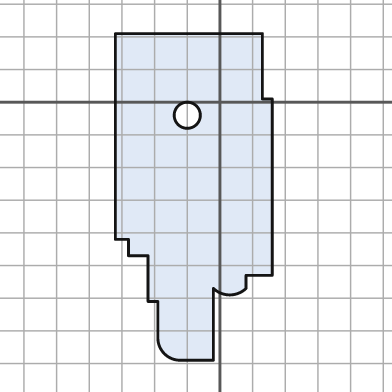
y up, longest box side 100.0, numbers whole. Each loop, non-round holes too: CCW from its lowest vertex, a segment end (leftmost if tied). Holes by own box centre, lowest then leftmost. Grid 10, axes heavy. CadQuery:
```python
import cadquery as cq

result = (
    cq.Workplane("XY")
    .moveTo(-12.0, -79.0)
    .lineTo(-2.0, -79.0)
    .lineTo(-2.0, -57.0)
    .threePointArc((3.0, -59.0), (8.0, -57.0))
    .lineTo(8.0, -53.0)
    .lineTo(16.0, -53.0)
    .lineTo(16.0, 1.0)
    .lineTo(13.0, 1.0)
    .lineTo(13.0, 21.0)
    .lineTo(-32.0, 21.0)
    .lineTo(-32.0, -42.0)
    .lineTo(-28.0, -42.0)
    .lineTo(-28.0, -47.0)
    .lineTo(-22.0, -47.0)
    .lineTo(-22.0, -61.0)
    .lineTo(-19.0, -61.0)
    .lineTo(-19.0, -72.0)
    .threePointArc((-17.0, -77.0), (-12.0, -79.0))
    .close()
    .moveTo(-10.0, -4.0)
    .circle(4.0)
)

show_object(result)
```